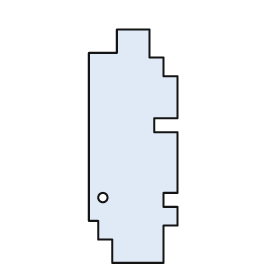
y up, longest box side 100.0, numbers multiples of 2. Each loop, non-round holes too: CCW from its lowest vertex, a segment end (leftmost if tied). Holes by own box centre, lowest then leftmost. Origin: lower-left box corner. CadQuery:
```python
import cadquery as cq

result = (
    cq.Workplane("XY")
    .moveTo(10.0, 0.0)
    .lineTo(32.0, 0.0)
    .lineTo(32.0, 16.0)
    .lineTo(38.0, 16.0)
    .lineTo(38.0, 24.0)
    .lineTo(32.0, 24.0)
    .lineTo(32.0, 30.0)
    .lineTo(38.0, 30.0)
    .lineTo(38.0, 56.0)
    .lineTo(28.0, 56.0)
    .lineTo(28.0, 62.0)
    .lineTo(38.0, 62.0)
    .lineTo(38.0, 80.0)
    .lineTo(32.0, 80.0)
    .lineTo(32.0, 88.0)
    .lineTo(26.0, 88.0)
    .lineTo(26.0, 100.0)
    .lineTo(12.0, 100.0)
    .lineTo(12.0, 90.0)
    .lineTo(0.0, 90.0)
    .lineTo(0.0, 18.0)
    .lineTo(4.0, 18.0)
    .lineTo(4.0, 10.0)
    .lineTo(10.0, 10.0)
    .close()
    .moveTo(6.0, 28.0)
    .circle(2.0)
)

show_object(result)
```